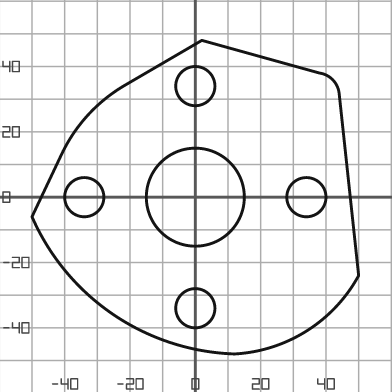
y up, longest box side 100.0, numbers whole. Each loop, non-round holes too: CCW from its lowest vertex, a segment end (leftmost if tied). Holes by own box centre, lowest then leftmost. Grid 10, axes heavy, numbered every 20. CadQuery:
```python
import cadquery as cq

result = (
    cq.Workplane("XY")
    .moveTo(12.0, -48.0)
    .threePointArc((34.0, -41.0), (50.0, -24.0))
    .lineTo(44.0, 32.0)
    .threePointArc((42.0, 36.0), (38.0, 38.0))
    .lineTo(2.0, 48.0)
    .lineTo(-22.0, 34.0)
    .threePointArc((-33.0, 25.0), (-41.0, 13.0))
    .lineTo(-50.0, -6.0)
    .threePointArc((-25.0, -36.0), (12.0, -48.0))
    .close()
    .moveTo(0.0, -34.0)
    .circle(6.0)
    .moveTo(-34.0, 0.0)
    .circle(6.0)
    .moveTo(0.0, 0.0)
    .circle(15.0)
    .moveTo(34.0, 0.0)
    .circle(6.0)
    .moveTo(0.0, 34.0)
    .circle(6.0)
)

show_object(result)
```